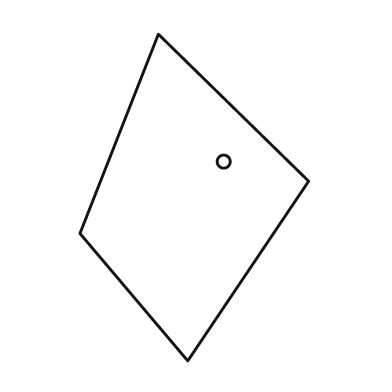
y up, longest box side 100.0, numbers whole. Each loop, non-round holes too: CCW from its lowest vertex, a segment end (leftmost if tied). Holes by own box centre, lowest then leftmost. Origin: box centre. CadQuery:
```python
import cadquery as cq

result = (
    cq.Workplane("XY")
    .moveTo(-2.0, -50.0)
    .lineTo(35.0, 5.0)
    .lineTo(-11.0, 50.0)
    .lineTo(-35.0, -11.0)
    .close()
    .moveTo(9.0, 11.0)
    .circle(2.0)
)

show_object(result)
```